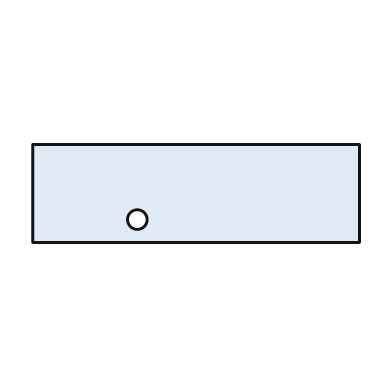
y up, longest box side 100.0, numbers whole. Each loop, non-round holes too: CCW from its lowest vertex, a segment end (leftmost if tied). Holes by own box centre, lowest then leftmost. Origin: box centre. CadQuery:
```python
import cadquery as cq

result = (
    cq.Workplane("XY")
    .moveTo(-50.0, -15.0)
    .lineTo(50.0, -15.0)
    .lineTo(50.0, 15.0)
    .lineTo(-50.0, 15.0)
    .close()
    .moveTo(-18.0, -8.0)
    .circle(3.0)
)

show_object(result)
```